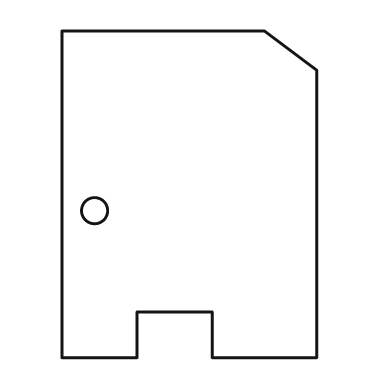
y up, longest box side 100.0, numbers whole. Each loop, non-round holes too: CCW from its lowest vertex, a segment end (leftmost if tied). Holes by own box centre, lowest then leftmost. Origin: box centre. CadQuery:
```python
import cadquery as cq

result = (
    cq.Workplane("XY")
    .moveTo(-39.0, -50.0)
    .lineTo(-16.0, -50.0)
    .lineTo(-16.0, -36.0)
    .lineTo(7.0, -36.0)
    .lineTo(7.0, -50.0)
    .lineTo(39.0, -50.0)
    .lineTo(39.0, 38.0)
    .lineTo(23.0, 50.0)
    .lineTo(-39.0, 50.0)
    .close()
    .moveTo(-29.0, -5.0)
    .circle(4.0)
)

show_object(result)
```